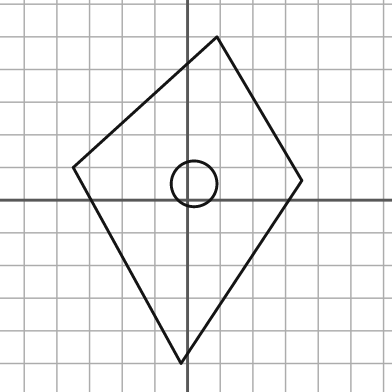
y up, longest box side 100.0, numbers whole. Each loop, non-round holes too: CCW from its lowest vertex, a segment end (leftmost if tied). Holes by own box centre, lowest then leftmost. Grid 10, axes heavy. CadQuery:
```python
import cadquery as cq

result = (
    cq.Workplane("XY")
    .moveTo(-2.0, -50.0)
    .lineTo(35.0, 6.0)
    .lineTo(9.0, 50.0)
    .lineTo(-35.0, 10.0)
    .close()
    .moveTo(2.0, 5.0)
    .circle(7.0)
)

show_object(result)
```